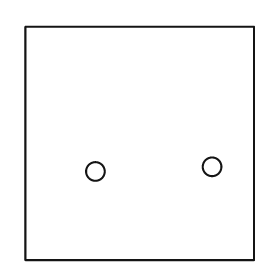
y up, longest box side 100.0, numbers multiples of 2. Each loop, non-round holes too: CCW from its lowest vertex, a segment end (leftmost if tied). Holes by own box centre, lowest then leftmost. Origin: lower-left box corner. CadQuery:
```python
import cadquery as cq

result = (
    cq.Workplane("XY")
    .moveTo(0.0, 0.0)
    .lineTo(98.0, 0.0)
    .lineTo(98.0, 100.0)
    .lineTo(0.0, 100.0)
    .close()
    .moveTo(30.0, 38.0)
    .circle(4.0)
    .moveTo(80.0, 40.0)
    .circle(4.0)
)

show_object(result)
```